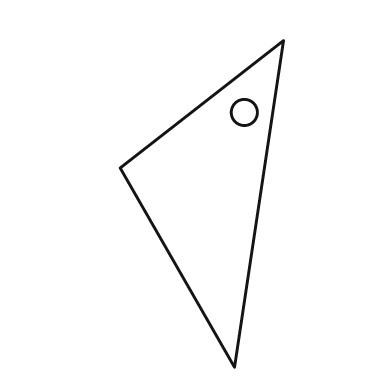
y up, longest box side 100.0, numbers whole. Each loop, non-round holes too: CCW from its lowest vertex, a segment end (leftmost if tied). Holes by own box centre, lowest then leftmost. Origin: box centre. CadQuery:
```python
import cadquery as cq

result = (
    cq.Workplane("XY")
    .moveTo(10.0, -50.0)
    .lineTo(25.0, 50.0)
    .lineTo(-25.0, 11.0)
    .close()
    .moveTo(13.0, 28.0)
    .circle(4.0)
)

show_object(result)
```